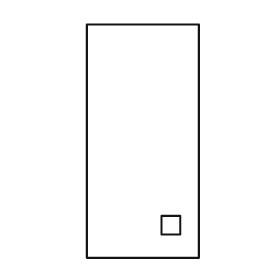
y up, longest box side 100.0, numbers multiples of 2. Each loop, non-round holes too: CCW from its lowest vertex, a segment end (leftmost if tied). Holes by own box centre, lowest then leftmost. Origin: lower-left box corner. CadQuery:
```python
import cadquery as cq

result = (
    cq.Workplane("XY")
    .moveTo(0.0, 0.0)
    .lineTo(48.0, 0.0)
    .lineTo(48.0, 100.0)
    .lineTo(0.0, 100.0)
    .close()
    .moveTo(32.0, 10.0)
    .lineTo(40.0, 10.0)
    .lineTo(40.0, 18.0)
    .lineTo(32.0, 18.0)
    .close()
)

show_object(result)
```